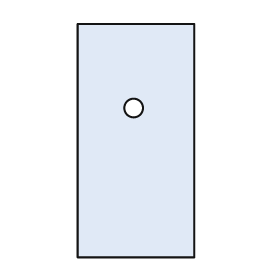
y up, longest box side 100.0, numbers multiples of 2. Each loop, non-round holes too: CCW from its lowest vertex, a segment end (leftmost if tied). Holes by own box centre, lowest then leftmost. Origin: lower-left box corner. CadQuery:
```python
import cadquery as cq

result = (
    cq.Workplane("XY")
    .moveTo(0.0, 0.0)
    .lineTo(50.0, 0.0)
    .lineTo(50.0, 100.0)
    .lineTo(0.0, 100.0)
    .close()
    .moveTo(24.0, 64.0)
    .circle(4.0)
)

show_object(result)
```